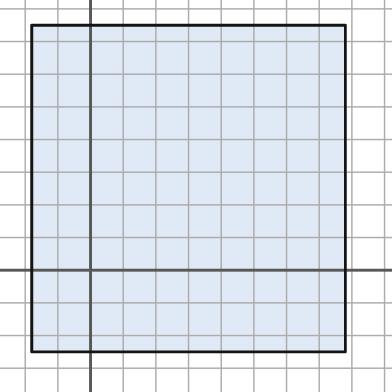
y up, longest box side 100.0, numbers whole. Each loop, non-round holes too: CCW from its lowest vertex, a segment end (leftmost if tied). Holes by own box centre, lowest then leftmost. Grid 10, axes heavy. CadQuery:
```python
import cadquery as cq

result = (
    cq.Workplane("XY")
    .moveTo(-18.0, -25.0)
    .lineTo(78.0, -25.0)
    .lineTo(78.0, 75.0)
    .lineTo(-18.0, 75.0)
    .close()
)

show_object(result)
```